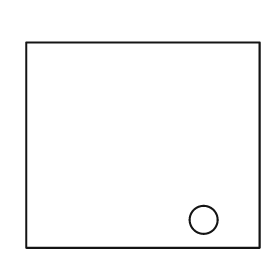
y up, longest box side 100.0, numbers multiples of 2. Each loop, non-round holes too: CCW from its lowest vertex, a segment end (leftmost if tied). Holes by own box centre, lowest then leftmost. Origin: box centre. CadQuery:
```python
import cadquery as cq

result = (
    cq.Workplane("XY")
    .moveTo(-50.0, -44.0)
    .lineTo(50.0, -44.0)
    .lineTo(50.0, 44.0)
    .lineTo(-50.0, 44.0)
    .close()
    .moveTo(26.0, -32.0)
    .circle(6.0)
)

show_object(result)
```